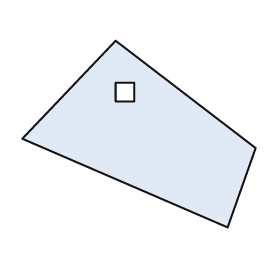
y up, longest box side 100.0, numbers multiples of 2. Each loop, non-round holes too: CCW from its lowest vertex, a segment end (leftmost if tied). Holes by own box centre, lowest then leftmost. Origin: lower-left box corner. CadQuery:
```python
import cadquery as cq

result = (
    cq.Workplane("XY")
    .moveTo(88.0, 0.0)
    .lineTo(100.0, 34.0)
    .lineTo(40.0, 80.0)
    .lineTo(0.0, 38.0)
    .close()
    .moveTo(40.0, 54.0)
    .lineTo(48.0, 54.0)
    .lineTo(48.0, 62.0)
    .lineTo(40.0, 62.0)
    .close()
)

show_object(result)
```